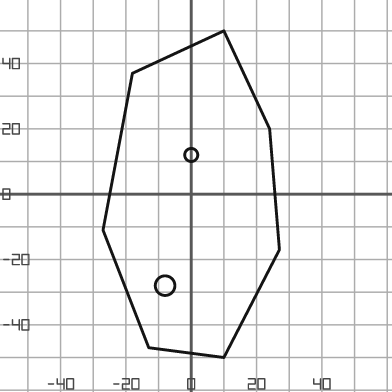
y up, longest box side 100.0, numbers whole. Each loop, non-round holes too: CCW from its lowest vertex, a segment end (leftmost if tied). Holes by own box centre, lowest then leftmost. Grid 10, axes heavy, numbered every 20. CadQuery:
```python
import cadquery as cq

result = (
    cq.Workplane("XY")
    .moveTo(10.0, -50.0)
    .lineTo(27.0, -17.0)
    .lineTo(24.0, 20.0)
    .lineTo(10.0, 50.0)
    .lineTo(-18.0, 37.0)
    .lineTo(-27.0, -11.0)
    .lineTo(-13.0, -47.0)
    .close()
    .moveTo(-8.0, -28.0)
    .circle(3.0)
    .moveTo(0.0, 12.0)
    .circle(2.0)
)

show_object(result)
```